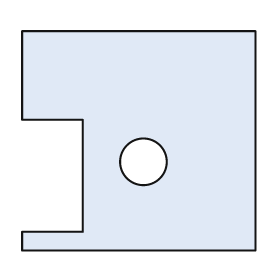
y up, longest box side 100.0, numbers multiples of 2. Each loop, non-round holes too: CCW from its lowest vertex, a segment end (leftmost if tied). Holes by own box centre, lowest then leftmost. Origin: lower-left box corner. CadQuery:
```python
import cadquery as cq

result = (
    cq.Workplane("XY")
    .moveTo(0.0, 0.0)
    .lineTo(100.0, 0.0)
    .lineTo(100.0, 94.0)
    .lineTo(0.0, 94.0)
    .lineTo(0.0, 56.0)
    .lineTo(26.0, 56.0)
    .lineTo(26.0, 8.0)
    .lineTo(0.0, 8.0)
    .close()
    .moveTo(52.0, 38.0)
    .circle(10.0)
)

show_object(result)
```